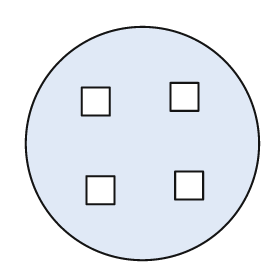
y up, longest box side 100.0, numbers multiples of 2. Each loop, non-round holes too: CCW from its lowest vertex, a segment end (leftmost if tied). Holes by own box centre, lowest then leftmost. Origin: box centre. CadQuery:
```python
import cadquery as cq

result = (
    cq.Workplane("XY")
    .moveTo(0.0, 0.0)
    .circle(50.0)
    .moveTo(-24.0, -26.0)
    .lineTo(-12.0, -26.0)
    .lineTo(-12.0, -14.0)
    .lineTo(-24.0, -14.0)
    .close()
    .moveTo(14.0, -24.0)
    .lineTo(26.0, -24.0)
    .lineTo(26.0, -12.0)
    .lineTo(14.0, -12.0)
    .close()
    .moveTo(-26.0, 12.0)
    .lineTo(-14.0, 12.0)
    .lineTo(-14.0, 24.0)
    .lineTo(-26.0, 24.0)
    .close()
    .moveTo(12.0, 14.0)
    .lineTo(24.0, 14.0)
    .lineTo(24.0, 26.0)
    .lineTo(12.0, 26.0)
    .close()
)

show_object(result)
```